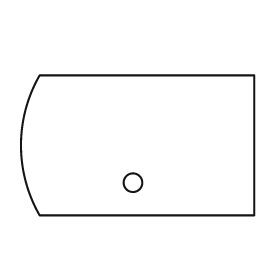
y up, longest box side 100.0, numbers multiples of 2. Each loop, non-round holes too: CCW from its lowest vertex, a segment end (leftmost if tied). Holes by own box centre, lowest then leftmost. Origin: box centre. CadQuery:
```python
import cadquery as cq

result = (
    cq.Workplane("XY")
    .moveTo(-42.0, -30.0)
    .lineTo(50.0, -30.0)
    .lineTo(50.0, 30.0)
    .lineTo(-42.0, 30.0)
    .threePointArc((-50.0, 0.0), (-42.0, -30.0))
    .close()
    .moveTo(-2.0, -16.0)
    .circle(4.0)
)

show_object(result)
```